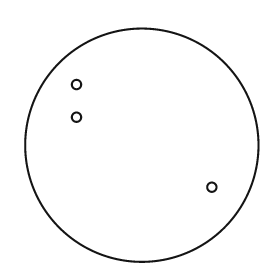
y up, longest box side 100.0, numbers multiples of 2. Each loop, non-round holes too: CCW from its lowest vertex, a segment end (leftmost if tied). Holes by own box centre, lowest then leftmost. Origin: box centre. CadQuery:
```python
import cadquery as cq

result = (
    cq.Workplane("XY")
    .moveTo(0.0, 0.0)
    .circle(50.0)
    .moveTo(30.0, -18.0)
    .circle(2.0)
    .moveTo(-28.0, 12.0)
    .circle(2.0)
    .moveTo(-28.0, 26.0)
    .circle(2.0)
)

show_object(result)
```